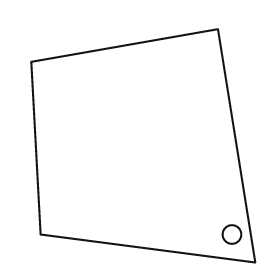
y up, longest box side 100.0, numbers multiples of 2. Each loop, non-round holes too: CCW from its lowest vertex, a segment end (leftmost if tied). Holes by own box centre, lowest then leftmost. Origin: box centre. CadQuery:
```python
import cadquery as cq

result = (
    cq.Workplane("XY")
    .moveTo(48.0, -50.0)
    .lineTo(32.0, 50.0)
    .lineTo(-48.0, 36.0)
    .lineTo(-44.0, -38.0)
    .close()
    .moveTo(38.0, -38.0)
    .circle(4.0)
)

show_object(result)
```